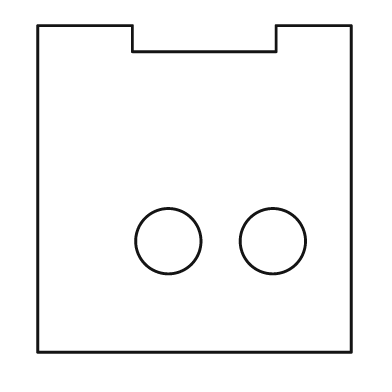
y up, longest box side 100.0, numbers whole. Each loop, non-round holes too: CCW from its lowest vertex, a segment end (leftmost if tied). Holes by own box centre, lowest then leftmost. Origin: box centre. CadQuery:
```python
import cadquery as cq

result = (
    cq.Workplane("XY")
    .moveTo(-48.0, -50.0)
    .lineTo(48.0, -50.0)
    .lineTo(48.0, 50.0)
    .lineTo(25.0, 50.0)
    .lineTo(25.0, 42.0)
    .lineTo(-19.0, 42.0)
    .lineTo(-19.0, 50.0)
    .lineTo(-48.0, 50.0)
    .close()
    .moveTo(-8.0, -16.0)
    .circle(10.0)
    .moveTo(24.0, -16.0)
    .circle(10.0)
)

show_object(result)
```